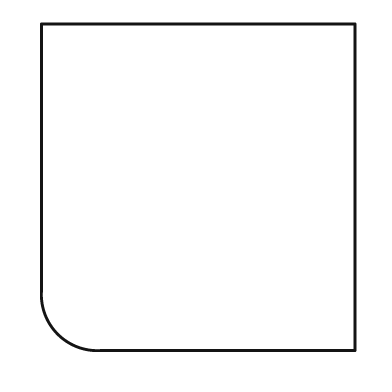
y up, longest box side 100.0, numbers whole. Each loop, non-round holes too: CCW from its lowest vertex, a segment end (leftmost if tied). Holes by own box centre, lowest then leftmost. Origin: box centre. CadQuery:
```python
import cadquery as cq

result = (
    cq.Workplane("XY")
    .moveTo(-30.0, -50.0)
    .lineTo(48.0, -50.0)
    .lineTo(48.0, 50.0)
    .lineTo(-48.0, 50.0)
    .lineTo(-48.0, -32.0)
    .threePointArc((-43.0, -45.0), (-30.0, -50.0))
    .close()
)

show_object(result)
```